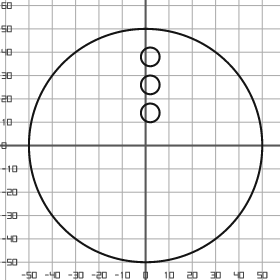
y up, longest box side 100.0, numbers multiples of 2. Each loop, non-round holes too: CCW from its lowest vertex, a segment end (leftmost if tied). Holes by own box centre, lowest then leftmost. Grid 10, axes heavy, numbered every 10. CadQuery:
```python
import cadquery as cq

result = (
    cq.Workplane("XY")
    .moveTo(0.0, 0.0)
    .circle(50.0)
    .moveTo(2.0, 14.0)
    .circle(4.0)
    .moveTo(2.0, 26.0)
    .circle(4.0)
    .moveTo(2.0, 38.0)
    .circle(4.0)
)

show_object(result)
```